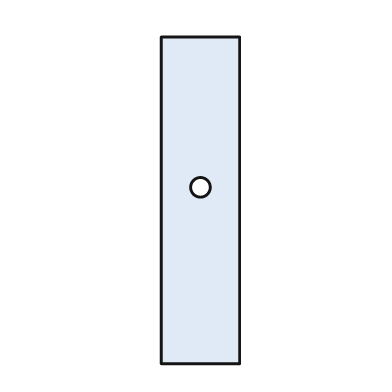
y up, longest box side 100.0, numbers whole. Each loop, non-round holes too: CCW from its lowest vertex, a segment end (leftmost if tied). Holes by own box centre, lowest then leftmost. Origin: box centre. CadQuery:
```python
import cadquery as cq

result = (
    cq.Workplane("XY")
    .moveTo(-12.0, -50.0)
    .lineTo(12.0, -50.0)
    .lineTo(12.0, 50.0)
    .lineTo(-12.0, 50.0)
    .close()
    .moveTo(0.0, 4.0)
    .circle(3.0)
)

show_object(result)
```